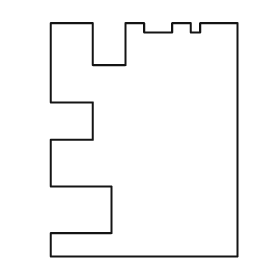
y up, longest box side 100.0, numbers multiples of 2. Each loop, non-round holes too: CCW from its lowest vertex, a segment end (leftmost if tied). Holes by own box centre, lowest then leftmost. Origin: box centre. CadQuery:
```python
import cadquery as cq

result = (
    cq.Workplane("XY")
    .moveTo(-40.0, -50.0)
    .lineTo(40.0, -50.0)
    .lineTo(40.0, 50.0)
    .lineTo(24.0, 50.0)
    .lineTo(24.0, 46.0)
    .lineTo(20.0, 46.0)
    .lineTo(20.0, 50.0)
    .lineTo(12.0, 50.0)
    .lineTo(12.0, 46.0)
    .lineTo(0.0, 46.0)
    .lineTo(0.0, 50.0)
    .lineTo(-8.0, 50.0)
    .lineTo(-8.0, 32.0)
    .lineTo(-22.0, 32.0)
    .lineTo(-22.0, 50.0)
    .lineTo(-40.0, 50.0)
    .lineTo(-40.0, 16.0)
    .lineTo(-22.0, 16.0)
    .lineTo(-22.0, 0.0)
    .lineTo(-40.0, 0.0)
    .lineTo(-40.0, -20.0)
    .lineTo(-14.0, -20.0)
    .lineTo(-14.0, -40.0)
    .lineTo(-40.0, -40.0)
    .close()
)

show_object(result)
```